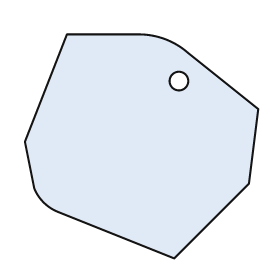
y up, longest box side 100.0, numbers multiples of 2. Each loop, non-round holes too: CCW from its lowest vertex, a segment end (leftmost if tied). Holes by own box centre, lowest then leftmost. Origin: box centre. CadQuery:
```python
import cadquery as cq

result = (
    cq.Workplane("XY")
    .moveTo(14.0, -48.0)
    .lineTo(46.0, -16.0)
    .lineTo(50.0, 16.0)
    .lineTo(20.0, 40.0)
    .threePointArc((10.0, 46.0), (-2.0, 48.0))
    .lineTo(-32.0, 48.0)
    .lineTo(-50.0, 2.0)
    .lineTo(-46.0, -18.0)
    .threePointArc((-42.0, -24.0), (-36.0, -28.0))
    .close()
    .moveTo(16.0, 28.0)
    .circle(4.0)
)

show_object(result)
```